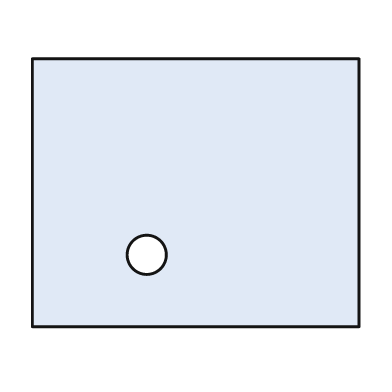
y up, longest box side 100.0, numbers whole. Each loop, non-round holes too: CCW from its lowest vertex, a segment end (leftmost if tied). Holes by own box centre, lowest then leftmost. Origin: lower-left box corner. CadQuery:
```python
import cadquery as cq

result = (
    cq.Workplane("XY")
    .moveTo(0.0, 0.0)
    .lineTo(100.0, 0.0)
    .lineTo(100.0, 82.0)
    .lineTo(0.0, 82.0)
    .close()
    .moveTo(35.0, 22.0)
    .circle(6.0)
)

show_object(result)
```